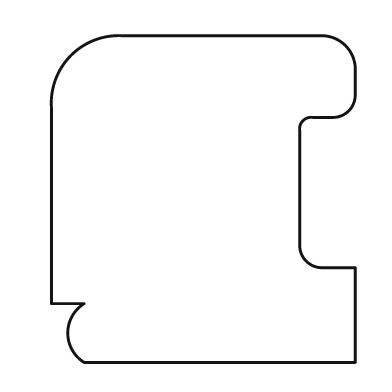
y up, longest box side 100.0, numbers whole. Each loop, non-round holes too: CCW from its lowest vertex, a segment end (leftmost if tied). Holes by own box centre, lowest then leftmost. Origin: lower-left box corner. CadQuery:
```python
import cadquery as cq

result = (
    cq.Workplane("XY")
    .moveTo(10.0, 0.0)
    .lineTo(93.0, 0.0)
    .lineTo(93.0, 29.0)
    .lineTo(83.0, 29.0)
    .threePointArc((78.0, 31.0), (76.0, 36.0))
    .lineTo(76.0, 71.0)
    .threePointArc((77.0, 74.0), (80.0, 75.0))
    .lineTo(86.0, 75.0)
    .threePointArc((91.0, 77.0), (93.0, 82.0))
    .lineTo(93.0, 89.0)
    .threePointArc((90.0, 97.0), (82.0, 100.0))
    .lineTo(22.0, 100.0)
    .threePointArc((6.0, 94.0), (0.0, 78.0))
    .lineTo(0.0, 18.0)
    .lineTo(10.0, 18.0)
    .threePointArc((5.0, 9.0), (10.0, 0.0))
    .close()
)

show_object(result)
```